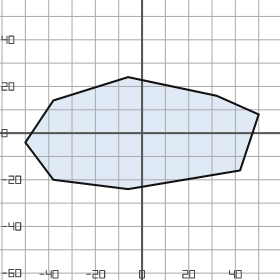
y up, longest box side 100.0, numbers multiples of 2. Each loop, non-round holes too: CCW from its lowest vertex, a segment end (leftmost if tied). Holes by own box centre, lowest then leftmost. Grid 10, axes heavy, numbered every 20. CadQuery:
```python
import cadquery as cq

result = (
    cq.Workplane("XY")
    .moveTo(-6.0, -24.0)
    .lineTo(42.0, -16.0)
    .lineTo(50.0, 8.0)
    .lineTo(32.0, 16.0)
    .lineTo(-6.0, 24.0)
    .lineTo(-38.0, 14.0)
    .lineTo(-50.0, -4.0)
    .lineTo(-38.0, -20.0)
    .close()
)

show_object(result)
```